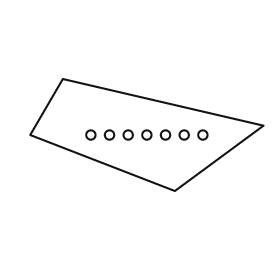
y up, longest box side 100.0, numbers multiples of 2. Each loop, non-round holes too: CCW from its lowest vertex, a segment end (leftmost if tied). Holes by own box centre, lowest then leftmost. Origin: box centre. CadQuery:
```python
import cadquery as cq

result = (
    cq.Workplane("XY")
    .moveTo(12.0, -24.0)
    .lineTo(50.0, 4.0)
    .lineTo(-36.0, 24.0)
    .lineTo(-50.0, 0.0)
    .close()
    .moveTo(-24.0, 0.0)
    .circle(2.0)
    .moveTo(-16.0, 0.0)
    .circle(2.0)
    .moveTo(-8.0, 0.0)
    .circle(2.0)
    .moveTo(0.0, 0.0)
    .circle(2.0)
    .moveTo(8.0, 0.0)
    .circle(2.0)
    .moveTo(16.0, 0.0)
    .circle(2.0)
    .moveTo(24.0, 0.0)
    .circle(2.0)
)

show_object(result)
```